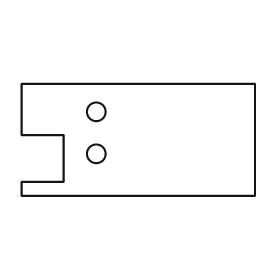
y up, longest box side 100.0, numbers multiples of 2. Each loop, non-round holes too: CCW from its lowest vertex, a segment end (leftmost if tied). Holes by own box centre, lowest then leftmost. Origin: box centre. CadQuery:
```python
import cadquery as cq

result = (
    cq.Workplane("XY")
    .moveTo(-50.0, -24.0)
    .lineTo(50.0, -24.0)
    .lineTo(50.0, 24.0)
    .lineTo(-50.0, 24.0)
    .lineTo(-50.0, 2.0)
    .lineTo(-32.0, 2.0)
    .lineTo(-32.0, -18.0)
    .lineTo(-50.0, -18.0)
    .close()
    .moveTo(-18.0, -6.0)
    .circle(4.0)
    .moveTo(-18.0, 12.0)
    .circle(4.0)
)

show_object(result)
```